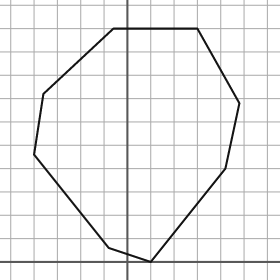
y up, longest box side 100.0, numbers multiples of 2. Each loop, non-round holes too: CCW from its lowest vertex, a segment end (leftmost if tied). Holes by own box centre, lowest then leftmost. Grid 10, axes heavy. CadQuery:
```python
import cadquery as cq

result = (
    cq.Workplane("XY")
    .moveTo(10.0, 0.0)
    .lineTo(42.0, 40.0)
    .lineTo(48.0, 68.0)
    .lineTo(30.0, 100.0)
    .lineTo(-6.0, 100.0)
    .lineTo(-36.0, 72.0)
    .lineTo(-40.0, 46.0)
    .lineTo(-8.0, 6.0)
    .close()
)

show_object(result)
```